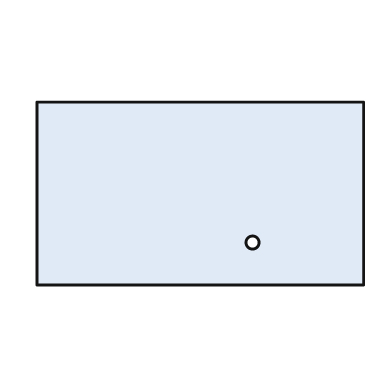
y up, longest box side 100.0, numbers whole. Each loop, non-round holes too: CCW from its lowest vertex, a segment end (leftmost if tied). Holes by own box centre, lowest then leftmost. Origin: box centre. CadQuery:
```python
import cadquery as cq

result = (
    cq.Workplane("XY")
    .moveTo(-50.0, -28.0)
    .lineTo(50.0, -28.0)
    .lineTo(50.0, 28.0)
    .lineTo(-50.0, 28.0)
    .close()
    .moveTo(16.0, -15.0)
    .circle(2.0)
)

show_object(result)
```